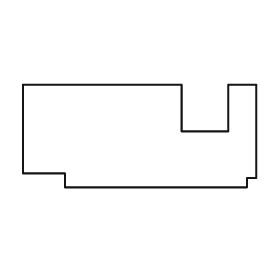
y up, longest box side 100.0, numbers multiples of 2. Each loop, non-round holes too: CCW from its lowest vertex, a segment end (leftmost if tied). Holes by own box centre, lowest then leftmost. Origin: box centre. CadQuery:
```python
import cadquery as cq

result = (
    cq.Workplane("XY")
    .moveTo(-32.0, -22.0)
    .lineTo(46.0, -22.0)
    .lineTo(46.0, -18.0)
    .lineTo(50.0, -18.0)
    .lineTo(50.0, 22.0)
    .lineTo(38.0, 22.0)
    .lineTo(38.0, 2.0)
    .lineTo(18.0, 2.0)
    .lineTo(18.0, 22.0)
    .lineTo(-50.0, 22.0)
    .lineTo(-50.0, -16.0)
    .lineTo(-32.0, -16.0)
    .close()
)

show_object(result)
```